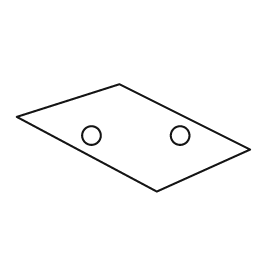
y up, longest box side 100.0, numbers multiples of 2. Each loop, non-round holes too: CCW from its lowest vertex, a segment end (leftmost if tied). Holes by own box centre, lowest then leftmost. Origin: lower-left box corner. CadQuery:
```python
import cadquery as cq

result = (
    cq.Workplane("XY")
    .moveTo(60.0, 0.0)
    .lineTo(100.0, 18.0)
    .lineTo(44.0, 46.0)
    .lineTo(0.0, 32.0)
    .close()
    .moveTo(32.0, 24.0)
    .circle(4.0)
    .moveTo(70.0, 24.0)
    .circle(4.0)
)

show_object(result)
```